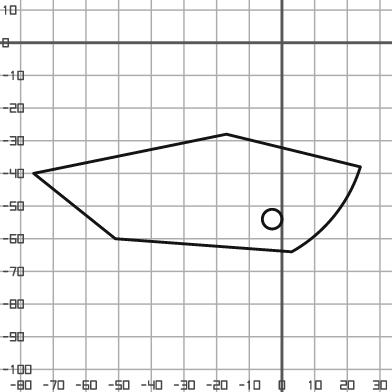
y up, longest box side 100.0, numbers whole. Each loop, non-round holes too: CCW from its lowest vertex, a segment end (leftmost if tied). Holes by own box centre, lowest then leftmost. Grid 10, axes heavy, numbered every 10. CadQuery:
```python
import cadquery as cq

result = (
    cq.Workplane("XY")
    .moveTo(3.0, -64.0)
    .threePointArc((16.0, -53.0), (24.0, -38.0))
    .lineTo(-17.0, -28.0)
    .lineTo(-76.0, -40.0)
    .lineTo(-51.0, -60.0)
    .close()
    .moveTo(-3.0, -54.0)
    .circle(3.0)
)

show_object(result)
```